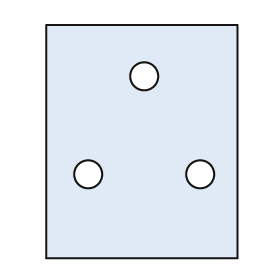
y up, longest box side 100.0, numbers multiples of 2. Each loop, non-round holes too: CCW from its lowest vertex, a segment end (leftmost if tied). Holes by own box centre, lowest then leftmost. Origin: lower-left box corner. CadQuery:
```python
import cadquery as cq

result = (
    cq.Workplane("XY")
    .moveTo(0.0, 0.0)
    .lineTo(82.0, 0.0)
    .lineTo(82.0, 100.0)
    .lineTo(0.0, 100.0)
    .close()
    .moveTo(18.0, 36.0)
    .circle(6.0)
    .moveTo(66.0, 36.0)
    .circle(6.0)
    .moveTo(42.0, 78.0)
    .circle(6.0)
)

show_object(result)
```